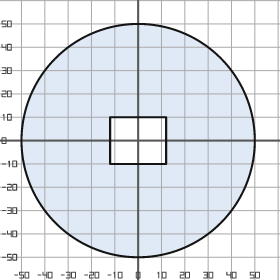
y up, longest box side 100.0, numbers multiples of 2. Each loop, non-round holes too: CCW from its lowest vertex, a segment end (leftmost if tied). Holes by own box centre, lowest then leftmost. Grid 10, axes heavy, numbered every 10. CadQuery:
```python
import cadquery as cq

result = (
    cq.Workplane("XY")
    .moveTo(0.0, 0.0)
    .circle(50.0)
    .moveTo(-12.0, -10.0)
    .lineTo(12.0, -10.0)
    .lineTo(12.0, 10.0)
    .lineTo(-12.0, 10.0)
    .close()
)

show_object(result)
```